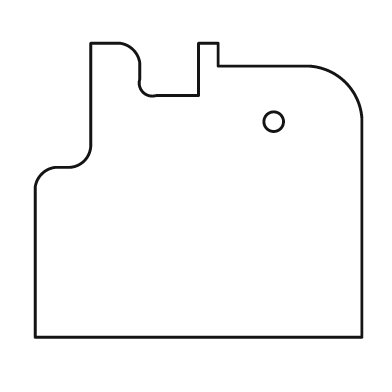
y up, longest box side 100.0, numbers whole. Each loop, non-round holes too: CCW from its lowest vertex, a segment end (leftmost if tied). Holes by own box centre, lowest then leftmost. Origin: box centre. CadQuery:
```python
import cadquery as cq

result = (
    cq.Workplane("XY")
    .moveTo(-50.0, -45.0)
    .lineTo(50.0, -45.0)
    .lineTo(50.0, 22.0)
    .threePointArc((45.0, 33.0), (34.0, 38.0))
    .lineTo(6.0, 38.0)
    .lineTo(6.0, 45.0)
    .lineTo(0.0, 45.0)
    .lineTo(0.0, 29.0)
    .lineTo(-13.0, 29.0)
    .threePointArc((-17.0, 30.0), (-18.0, 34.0))
    .lineTo(-18.0, 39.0)
    .threePointArc((-20.0, 43.0), (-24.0, 45.0))
    .lineTo(-33.0, 45.0)
    .lineTo(-33.0, 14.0)
    .threePointArc((-35.0, 9.0), (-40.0, 7.0))
    .lineTo(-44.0, 7.0)
    .threePointArc((-48.0, 5.0), (-50.0, 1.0))
    .close()
    .moveTo(23.0, 21.0)
    .circle(3.0)
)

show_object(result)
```